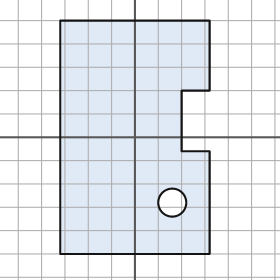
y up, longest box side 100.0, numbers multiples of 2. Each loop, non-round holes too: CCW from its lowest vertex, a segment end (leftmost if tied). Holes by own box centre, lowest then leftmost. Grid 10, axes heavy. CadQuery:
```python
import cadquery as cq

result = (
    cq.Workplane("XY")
    .moveTo(-32.0, -50.0)
    .lineTo(32.0, -50.0)
    .lineTo(32.0, -6.0)
    .lineTo(20.0, -6.0)
    .lineTo(20.0, 20.0)
    .lineTo(32.0, 20.0)
    .lineTo(32.0, 50.0)
    .lineTo(-32.0, 50.0)
    .close()
    .moveTo(16.0, -28.0)
    .circle(6.0)
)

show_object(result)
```